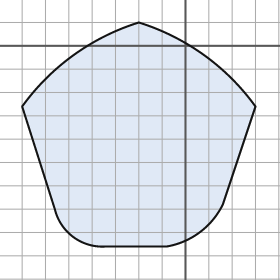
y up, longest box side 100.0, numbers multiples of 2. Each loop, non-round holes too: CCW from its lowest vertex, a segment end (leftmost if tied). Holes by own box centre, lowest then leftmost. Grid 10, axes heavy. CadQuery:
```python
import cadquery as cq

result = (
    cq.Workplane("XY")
    .moveTo(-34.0, -86.0)
    .lineTo(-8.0, -86.0)
    .threePointArc((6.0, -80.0), (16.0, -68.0))
    .lineTo(30.0, -26.0)
    .threePointArc((8.0, -4.0), (-20.0, 10.0))
    .threePointArc((-48.0, -4.0), (-70.0, -26.0))
    .lineTo(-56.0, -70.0)
    .threePointArc((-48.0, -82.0), (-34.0, -86.0))
    .close()
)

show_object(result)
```